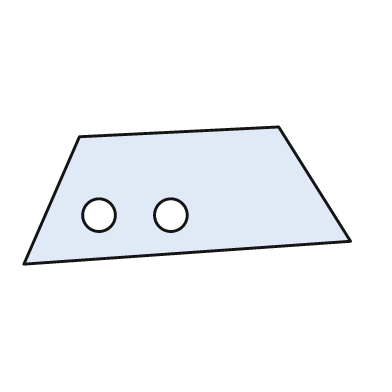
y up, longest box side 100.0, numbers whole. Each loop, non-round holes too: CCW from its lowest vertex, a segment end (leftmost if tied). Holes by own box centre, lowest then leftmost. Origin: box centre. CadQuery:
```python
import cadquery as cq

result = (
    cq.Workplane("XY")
    .moveTo(-50.0, -21.0)
    .lineTo(50.0, -14.0)
    .lineTo(28.0, 21.0)
    .lineTo(-33.0, 18.0)
    .close()
    .moveTo(-27.0, -6.0)
    .circle(5.0)
    .moveTo(-5.0, -6.0)
    .circle(5.0)
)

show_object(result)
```